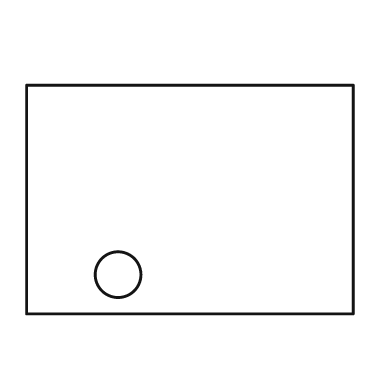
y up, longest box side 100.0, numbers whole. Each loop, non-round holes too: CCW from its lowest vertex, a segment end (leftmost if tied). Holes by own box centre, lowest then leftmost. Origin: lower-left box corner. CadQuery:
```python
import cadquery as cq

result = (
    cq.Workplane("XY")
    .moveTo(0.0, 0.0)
    .lineTo(100.0, 0.0)
    .lineTo(100.0, 70.0)
    .lineTo(0.0, 70.0)
    .close()
    .moveTo(28.0, 12.0)
    .circle(7.0)
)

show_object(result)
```